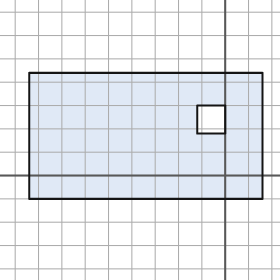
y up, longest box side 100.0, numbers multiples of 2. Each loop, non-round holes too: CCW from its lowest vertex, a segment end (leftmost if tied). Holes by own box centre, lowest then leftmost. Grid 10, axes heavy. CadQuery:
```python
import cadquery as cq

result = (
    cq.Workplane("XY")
    .moveTo(-84.0, -10.0)
    .lineTo(16.0, -10.0)
    .lineTo(16.0, 44.0)
    .lineTo(-84.0, 44.0)
    .close()
    .moveTo(-12.0, 18.0)
    .lineTo(0.0, 18.0)
    .lineTo(0.0, 30.0)
    .lineTo(-12.0, 30.0)
    .close()
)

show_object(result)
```